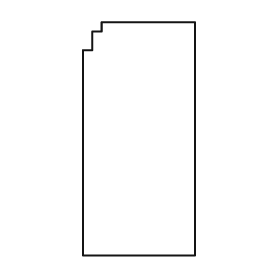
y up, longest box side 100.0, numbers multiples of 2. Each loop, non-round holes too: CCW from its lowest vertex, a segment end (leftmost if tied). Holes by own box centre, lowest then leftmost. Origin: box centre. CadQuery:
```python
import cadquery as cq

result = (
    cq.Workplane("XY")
    .moveTo(-24.0, -50.0)
    .lineTo(24.0, -50.0)
    .lineTo(24.0, 50.0)
    .lineTo(-16.0, 50.0)
    .lineTo(-16.0, 46.0)
    .lineTo(-20.0, 46.0)
    .lineTo(-20.0, 38.0)
    .lineTo(-24.0, 38.0)
    .close()
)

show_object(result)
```